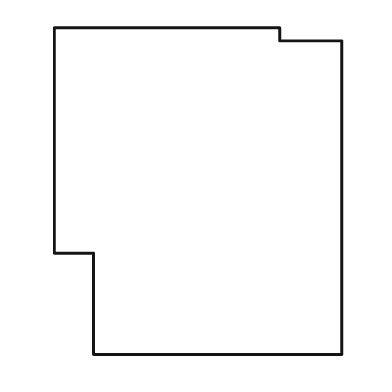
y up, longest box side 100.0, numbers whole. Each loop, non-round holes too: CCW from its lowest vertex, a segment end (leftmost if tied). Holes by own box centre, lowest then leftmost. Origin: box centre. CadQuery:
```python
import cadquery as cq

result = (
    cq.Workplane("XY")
    .moveTo(-32.0, -50.0)
    .lineTo(44.0, -50.0)
    .lineTo(44.0, 46.0)
    .lineTo(25.0, 46.0)
    .lineTo(25.0, 50.0)
    .lineTo(-44.0, 50.0)
    .lineTo(-44.0, -19.0)
    .lineTo(-32.0, -19.0)
    .close()
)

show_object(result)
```